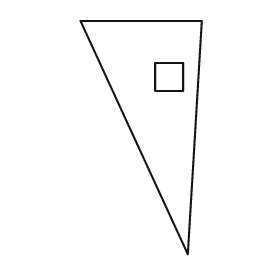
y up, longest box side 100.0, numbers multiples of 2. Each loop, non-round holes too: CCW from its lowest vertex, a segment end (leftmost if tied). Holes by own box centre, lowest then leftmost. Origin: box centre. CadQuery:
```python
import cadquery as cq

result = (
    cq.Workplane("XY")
    .moveTo(20.0, -50.0)
    .lineTo(26.0, 50.0)
    .lineTo(-26.0, 50.0)
    .close()
    .moveTo(6.0, 20.0)
    .lineTo(18.0, 20.0)
    .lineTo(18.0, 32.0)
    .lineTo(6.0, 32.0)
    .close()
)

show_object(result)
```